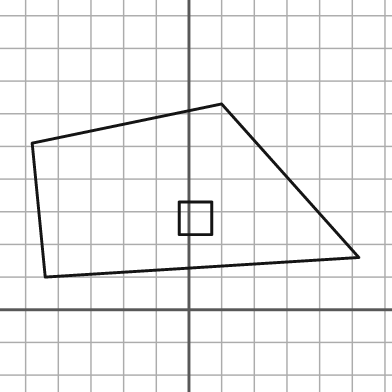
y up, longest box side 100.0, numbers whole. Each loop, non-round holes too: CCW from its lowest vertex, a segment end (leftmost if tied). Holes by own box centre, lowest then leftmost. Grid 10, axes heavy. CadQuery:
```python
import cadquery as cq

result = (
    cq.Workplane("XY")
    .moveTo(-44.0, 10.0)
    .lineTo(52.0, 16.0)
    .lineTo(10.0, 63.0)
    .lineTo(-48.0, 51.0)
    .close()
    .moveTo(-3.0, 23.0)
    .lineTo(7.0, 23.0)
    .lineTo(7.0, 33.0)
    .lineTo(-3.0, 33.0)
    .close()
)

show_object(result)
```